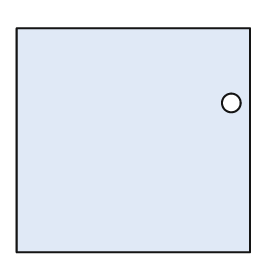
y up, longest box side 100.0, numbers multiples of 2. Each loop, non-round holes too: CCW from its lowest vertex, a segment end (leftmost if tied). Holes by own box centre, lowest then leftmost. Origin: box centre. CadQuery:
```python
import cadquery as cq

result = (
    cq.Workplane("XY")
    .moveTo(-50.0, -48.0)
    .lineTo(50.0, -48.0)
    .lineTo(50.0, 48.0)
    .lineTo(-50.0, 48.0)
    .close()
    .moveTo(42.0, 16.0)
    .circle(4.0)
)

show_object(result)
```